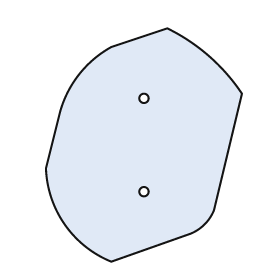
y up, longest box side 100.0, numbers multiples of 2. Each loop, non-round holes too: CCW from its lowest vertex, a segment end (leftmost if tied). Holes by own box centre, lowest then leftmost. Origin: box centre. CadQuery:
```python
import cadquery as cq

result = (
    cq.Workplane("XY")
    .moveTo(-14.0, -50.0)
    .lineTo(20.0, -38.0)
    .threePointArc((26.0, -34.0), (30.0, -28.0))
    .lineTo(42.0, 22.0)
    .threePointArc((28.0, 38.0), (10.0, 50.0))
    .lineTo(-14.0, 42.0)
    .threePointArc((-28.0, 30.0), (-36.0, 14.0))
    .lineTo(-42.0, -10.0)
    .threePointArc((-34.0, -34.0), (-14.0, -50.0))
    .close()
    .moveTo(0.0, -20.0)
    .circle(2.0)
    .moveTo(0.0, 20.0)
    .circle(2.0)
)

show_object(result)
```